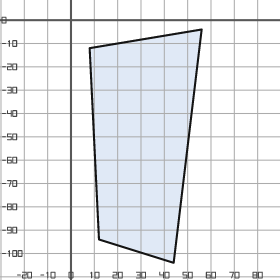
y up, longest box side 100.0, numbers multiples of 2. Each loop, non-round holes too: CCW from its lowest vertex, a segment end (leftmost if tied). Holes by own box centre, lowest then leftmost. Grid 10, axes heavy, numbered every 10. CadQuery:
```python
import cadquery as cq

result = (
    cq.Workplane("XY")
    .moveTo(44.0, -104.0)
    .lineTo(56.0, -4.0)
    .lineTo(8.0, -12.0)
    .lineTo(12.0, -94.0)
    .close()
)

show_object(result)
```